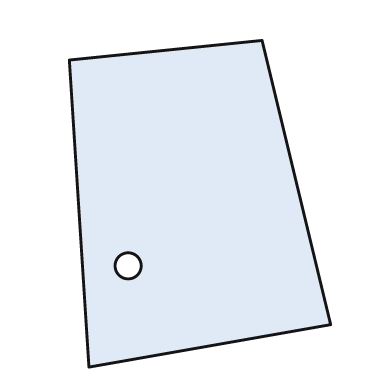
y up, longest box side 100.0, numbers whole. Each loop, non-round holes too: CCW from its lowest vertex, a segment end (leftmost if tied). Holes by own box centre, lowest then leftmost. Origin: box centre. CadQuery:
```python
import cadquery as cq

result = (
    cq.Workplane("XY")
    .moveTo(-34.0, -50.0)
    .lineTo(40.0, -37.0)
    .lineTo(19.0, 50.0)
    .lineTo(-40.0, 44.0)
    .close()
    .moveTo(-22.0, -19.0)
    .circle(4.0)
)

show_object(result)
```